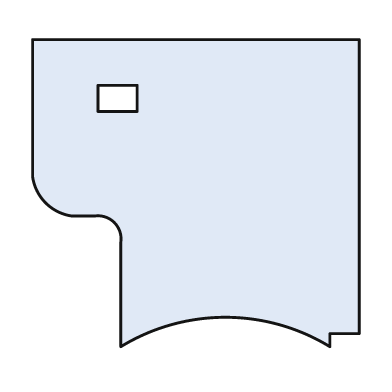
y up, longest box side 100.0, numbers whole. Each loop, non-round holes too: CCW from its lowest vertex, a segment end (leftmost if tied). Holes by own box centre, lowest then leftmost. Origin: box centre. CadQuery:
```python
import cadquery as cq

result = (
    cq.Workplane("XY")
    .moveTo(-23.0, -47.0)
    .threePointArc((9.0, -38.0), (41.0, -47.0))
    .lineTo(41.0, -43.0)
    .lineTo(50.0, -43.0)
    .lineTo(50.0, 47.0)
    .lineTo(-50.0, 47.0)
    .lineTo(-50.0, 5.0)
    .threePointArc((-46.0, -3.0), (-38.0, -7.0))
    .lineTo(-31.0, -7.0)
    .threePointArc((-25.0, -9.0), (-23.0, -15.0))
    .close()
    .moveTo(-30.0, 25.0)
    .lineTo(-18.0, 25.0)
    .lineTo(-18.0, 33.0)
    .lineTo(-30.0, 33.0)
    .close()
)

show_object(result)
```